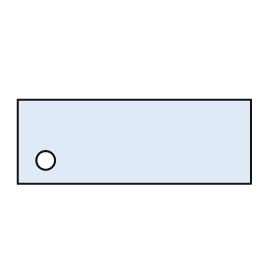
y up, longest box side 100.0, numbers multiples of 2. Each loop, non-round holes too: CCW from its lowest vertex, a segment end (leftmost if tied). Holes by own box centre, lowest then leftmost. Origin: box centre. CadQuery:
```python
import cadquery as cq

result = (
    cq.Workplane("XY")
    .moveTo(-50.0, -18.0)
    .lineTo(50.0, -18.0)
    .lineTo(50.0, 18.0)
    .lineTo(-50.0, 18.0)
    .close()
    .moveTo(-38.0, -8.0)
    .circle(4.0)
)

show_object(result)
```